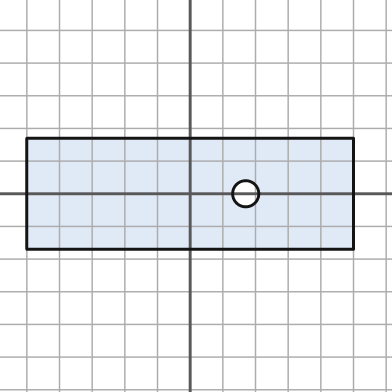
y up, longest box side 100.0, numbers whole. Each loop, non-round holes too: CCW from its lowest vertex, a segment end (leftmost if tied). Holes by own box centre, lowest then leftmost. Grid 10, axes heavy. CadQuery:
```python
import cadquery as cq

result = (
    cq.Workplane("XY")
    .moveTo(-50.0, -17.0)
    .lineTo(50.0, -17.0)
    .lineTo(50.0, 17.0)
    .lineTo(-50.0, 17.0)
    .close()
    .moveTo(17.0, 0.0)
    .circle(4.0)
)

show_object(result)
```